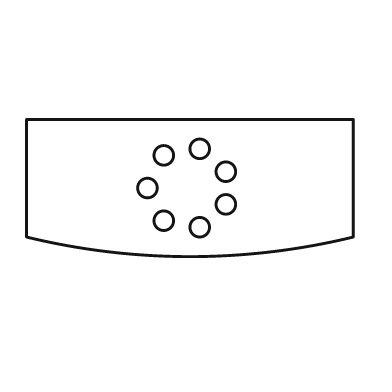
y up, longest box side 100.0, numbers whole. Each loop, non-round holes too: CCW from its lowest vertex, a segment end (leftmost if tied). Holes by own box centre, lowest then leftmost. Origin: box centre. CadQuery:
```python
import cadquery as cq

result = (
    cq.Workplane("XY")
    .moveTo(-50.0, -15.0)
    .threePointArc((0.0, -21.0), (50.0, -15.0))
    .lineTo(50.0, 21.0)
    .lineTo(-50.0, 21.0)
    .close()
    .moveTo(3.0, -12.0)
    .circle(3.0)
    .moveTo(-8.0, -10.0)
    .circle(3.0)
    .moveTo(11.0, -5.0)
    .circle(3.0)
    .moveTo(-13.0, 0.0)
    .circle(3.0)
    .moveTo(11.0, 5.0)
    .circle(3.0)
    .moveTo(-8.0, 10.0)
    .circle(3.0)
    .moveTo(3.0, 12.0)
    .circle(3.0)
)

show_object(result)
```